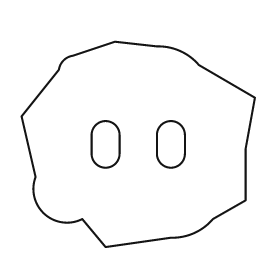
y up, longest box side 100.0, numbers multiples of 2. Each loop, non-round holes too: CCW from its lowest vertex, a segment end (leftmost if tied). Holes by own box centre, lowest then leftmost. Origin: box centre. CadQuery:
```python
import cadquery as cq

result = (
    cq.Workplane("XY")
    .moveTo(-14.0, -44.0)
    .lineTo(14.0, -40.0)
    .threePointArc((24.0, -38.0), (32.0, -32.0))
    .lineTo(46.0, -24.0)
    .lineTo(46.0, -2.0)
    .lineTo(50.0, 20.0)
    .lineTo(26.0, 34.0)
    .threePointArc((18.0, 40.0), (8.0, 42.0))
    .lineTo(-10.0, 44.0)
    .lineTo(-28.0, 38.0)
    .threePointArc((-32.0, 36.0), (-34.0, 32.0))
    .lineTo(-50.0, 12.0)
    .lineTo(-44.0, -14.0)
    .threePointArc((-40.0, -30.0), (-24.0, -32.0))
    .close()
    .moveTo(-20.0, -4.0)
    .threePointArc((-14.0, -10.0), (-8.0, -4.0))
    .lineTo(-8.0, 4.0)
    .threePointArc((-14.0, 10.0), (-20.0, 4.0))
    .close()
    .moveTo(8.0, -4.0)
    .threePointArc((14.0, -10.0), (20.0, -4.0))
    .lineTo(20.0, 4.0)
    .threePointArc((14.0, 10.0), (8.0, 4.0))
    .close()
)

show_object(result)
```